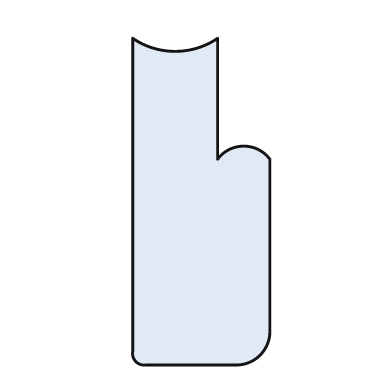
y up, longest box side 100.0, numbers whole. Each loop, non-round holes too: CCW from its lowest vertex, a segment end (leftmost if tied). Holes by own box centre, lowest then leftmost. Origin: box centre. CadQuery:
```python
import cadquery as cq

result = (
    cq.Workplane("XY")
    .moveTo(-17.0, -50.0)
    .lineTo(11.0, -50.0)
    .threePointArc((18.0, -47.0), (21.0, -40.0))
    .lineTo(21.0, 13.0)
    .threePointArc((13.0, 17.0), (5.0, 13.0))
    .lineTo(5.0, 50.0)
    .threePointArc((-8.0, 46.0), (-21.0, 50.0))
    .lineTo(-21.0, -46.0)
    .threePointArc((-20.0, -49.0), (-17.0, -50.0))
    .close()
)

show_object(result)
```